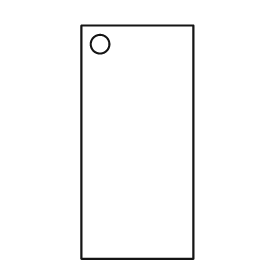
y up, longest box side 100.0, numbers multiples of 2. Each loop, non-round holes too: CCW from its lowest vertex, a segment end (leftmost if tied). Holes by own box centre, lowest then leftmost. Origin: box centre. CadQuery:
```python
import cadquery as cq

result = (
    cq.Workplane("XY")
    .moveTo(-24.0, -50.0)
    .lineTo(24.0, -50.0)
    .lineTo(24.0, 50.0)
    .lineTo(-24.0, 50.0)
    .close()
    .moveTo(-16.0, 42.0)
    .circle(4.0)
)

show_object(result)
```